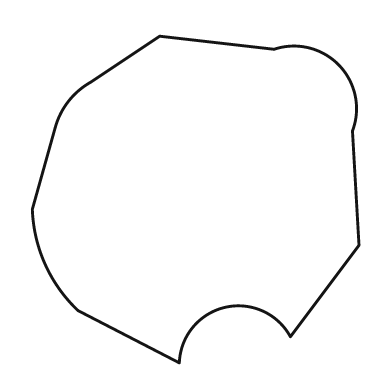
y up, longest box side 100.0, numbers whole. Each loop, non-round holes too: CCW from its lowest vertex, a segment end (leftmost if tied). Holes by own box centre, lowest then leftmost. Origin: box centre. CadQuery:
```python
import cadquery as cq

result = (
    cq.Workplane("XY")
    .moveTo(-5.0, -50.0)
    .threePointArc((9.0, -33.0), (29.0, -42.0))
    .lineTo(50.0, -14.0)
    .lineTo(48.0, 21.0)
    .threePointArc((44.0, 41.0), (24.0, 46.0))
    .lineTo(-11.0, 50.0)
    .lineTo(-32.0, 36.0)
    .threePointArc((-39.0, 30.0), (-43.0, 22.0))
    .lineTo(-50.0, -3.0)
    .threePointArc((-46.0, -20.0), (-36.0, -34.0))
    .close()
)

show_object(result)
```